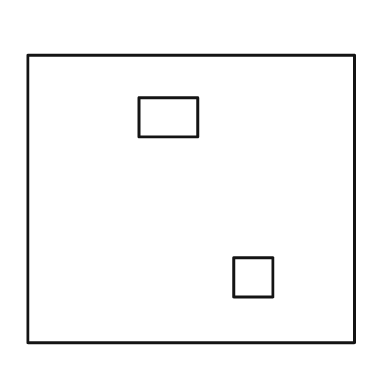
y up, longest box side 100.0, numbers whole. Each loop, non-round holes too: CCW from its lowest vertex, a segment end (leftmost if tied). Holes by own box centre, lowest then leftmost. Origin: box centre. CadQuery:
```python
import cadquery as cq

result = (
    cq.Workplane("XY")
    .moveTo(-50.0, -44.0)
    .lineTo(50.0, -44.0)
    .lineTo(50.0, 44.0)
    .lineTo(-50.0, 44.0)
    .close()
    .moveTo(13.0, -30.0)
    .lineTo(25.0, -30.0)
    .lineTo(25.0, -18.0)
    .lineTo(13.0, -18.0)
    .close()
    .moveTo(-16.0, 19.0)
    .lineTo(2.0, 19.0)
    .lineTo(2.0, 31.0)
    .lineTo(-16.0, 31.0)
    .close()
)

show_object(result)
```